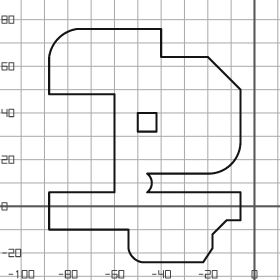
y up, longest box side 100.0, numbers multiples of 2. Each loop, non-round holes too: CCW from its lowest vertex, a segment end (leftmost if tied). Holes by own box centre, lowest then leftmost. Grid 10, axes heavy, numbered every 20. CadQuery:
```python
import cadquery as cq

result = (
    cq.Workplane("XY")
    .moveTo(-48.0, -24.0)
    .lineTo(-22.0, -24.0)
    .lineTo(-18.0, -18.0)
    .lineTo(-18.0, -12.0)
    .lineTo(-12.0, -6.0)
    .lineTo(-6.0, -6.0)
    .lineTo(-6.0, 6.0)
    .lineTo(-46.0, 6.0)
    .threePointArc((-44.0, 10.0), (-46.0, 14.0))
    .lineTo(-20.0, 14.0)
    .threePointArc((-10.0, 18.0), (-6.0, 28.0))
    .lineTo(-6.0, 50.0)
    .lineTo(-20.0, 64.0)
    .lineTo(-40.0, 64.0)
    .lineTo(-40.0, 76.0)
    .lineTo(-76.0, 76.0)
    .threePointArc((-84.0, 72.0), (-88.0, 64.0))
    .lineTo(-88.0, 48.0)
    .lineTo(-60.0, 48.0)
    .lineTo(-60.0, 6.0)
    .lineTo(-88.0, 6.0)
    .lineTo(-88.0, -10.0)
    .lineTo(-54.0, -10.0)
    .lineTo(-54.0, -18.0)
    .threePointArc((-52.0, -22.0), (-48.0, -24.0))
    .close()
    .moveTo(-50.0, 32.0)
    .lineTo(-42.0, 32.0)
    .lineTo(-42.0, 40.0)
    .lineTo(-50.0, 40.0)
    .close()
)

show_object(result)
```